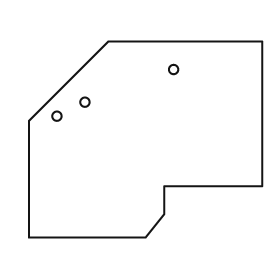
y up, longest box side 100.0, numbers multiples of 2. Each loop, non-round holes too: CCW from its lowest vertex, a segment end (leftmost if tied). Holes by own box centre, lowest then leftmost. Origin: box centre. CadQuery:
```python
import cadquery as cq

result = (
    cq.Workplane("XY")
    .moveTo(-50.0, -42.0)
    .lineTo(0.0, -42.0)
    .lineTo(8.0, -32.0)
    .lineTo(8.0, -20.0)
    .lineTo(50.0, -20.0)
    .lineTo(50.0, 42.0)
    .lineTo(-16.0, 42.0)
    .lineTo(-50.0, 8.0)
    .close()
    .moveTo(-38.0, 10.0)
    .circle(2.0)
    .moveTo(-26.0, 16.0)
    .circle(2.0)
    .moveTo(12.0, 30.0)
    .circle(2.0)
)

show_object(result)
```